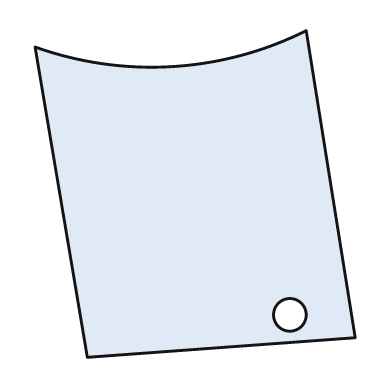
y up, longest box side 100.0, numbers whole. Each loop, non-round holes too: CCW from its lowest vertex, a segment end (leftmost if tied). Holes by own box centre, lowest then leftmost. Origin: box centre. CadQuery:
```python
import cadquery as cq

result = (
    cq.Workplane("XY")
    .moveTo(-33.0, -50.0)
    .lineTo(49.0, -44.0)
    .lineTo(34.0, 50.0)
    .threePointArc((-7.0, 39.0), (-49.0, 45.0))
    .close()
    .moveTo(29.0, -37.0)
    .circle(5.0)
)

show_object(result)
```